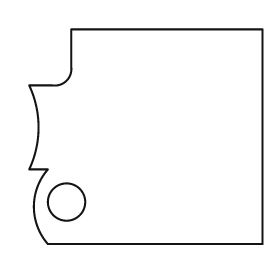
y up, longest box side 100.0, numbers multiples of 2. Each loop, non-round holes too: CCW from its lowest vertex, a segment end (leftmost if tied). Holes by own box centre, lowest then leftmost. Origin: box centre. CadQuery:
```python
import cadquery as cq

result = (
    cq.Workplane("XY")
    .moveTo(-42.0, -46.0)
    .lineTo(50.0, -46.0)
    .lineTo(50.0, 46.0)
    .lineTo(-32.0, 46.0)
    .lineTo(-32.0, 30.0)
    .threePointArc((-34.0, 24.0), (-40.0, 22.0))
    .lineTo(-50.0, 22.0)
    .threePointArc((-46.0, 4.0), (-50.0, -14.0))
    .lineTo(-42.0, -14.0)
    .threePointArc((-48.0, -30.0), (-42.0, -46.0))
    .close()
    .moveTo(-34.0, -28.0)
    .circle(8.0)
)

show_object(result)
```